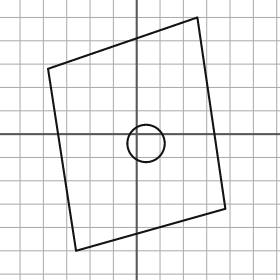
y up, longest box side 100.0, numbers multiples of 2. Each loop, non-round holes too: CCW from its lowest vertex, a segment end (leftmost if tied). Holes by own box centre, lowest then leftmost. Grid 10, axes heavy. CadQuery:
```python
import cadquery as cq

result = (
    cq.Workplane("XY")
    .moveTo(-26.0, -50.0)
    .lineTo(38.0, -32.0)
    .lineTo(26.0, 50.0)
    .lineTo(-38.0, 28.0)
    .close()
    .moveTo(4.0, -4.0)
    .circle(8.0)
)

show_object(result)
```